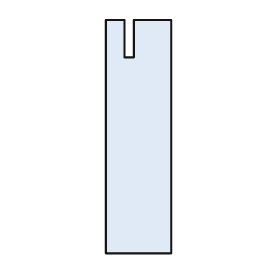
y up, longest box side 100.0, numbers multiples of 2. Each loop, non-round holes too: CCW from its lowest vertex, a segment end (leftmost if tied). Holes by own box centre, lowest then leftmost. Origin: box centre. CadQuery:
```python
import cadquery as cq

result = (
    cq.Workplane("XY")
    .moveTo(-14.0, -50.0)
    .lineTo(14.0, -50.0)
    .lineTo(14.0, 50.0)
    .lineTo(-2.0, 50.0)
    .lineTo(-2.0, 34.0)
    .lineTo(-6.0, 34.0)
    .lineTo(-6.0, 50.0)
    .lineTo(-14.0, 50.0)
    .close()
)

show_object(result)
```